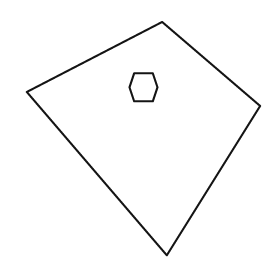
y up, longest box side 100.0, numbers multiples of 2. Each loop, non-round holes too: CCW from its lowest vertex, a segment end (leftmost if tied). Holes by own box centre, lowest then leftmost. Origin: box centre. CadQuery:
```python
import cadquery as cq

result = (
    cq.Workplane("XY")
    .moveTo(10.0, -50.0)
    .lineTo(50.0, 14.0)
    .lineTo(8.0, 50.0)
    .lineTo(-50.0, 20.0)
    .close()
    .moveTo(-4.0, 16.0)
    .lineTo(4.0, 16.0)
    .lineTo(6.0, 22.0)
    .lineTo(4.0, 28.0)
    .lineTo(-4.0, 28.0)
    .lineTo(-6.0, 22.0)
    .close()
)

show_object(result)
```